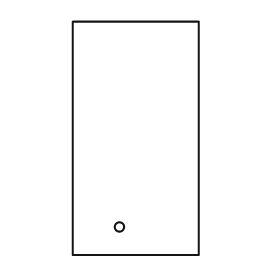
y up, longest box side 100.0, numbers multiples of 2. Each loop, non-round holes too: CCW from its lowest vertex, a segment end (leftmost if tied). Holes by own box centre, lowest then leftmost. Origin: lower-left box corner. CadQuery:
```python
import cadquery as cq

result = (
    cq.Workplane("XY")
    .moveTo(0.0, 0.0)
    .lineTo(54.0, 0.0)
    .lineTo(54.0, 100.0)
    .lineTo(0.0, 100.0)
    .close()
    .moveTo(20.0, 12.0)
    .circle(2.0)
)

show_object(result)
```